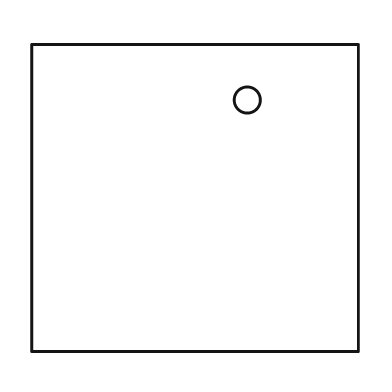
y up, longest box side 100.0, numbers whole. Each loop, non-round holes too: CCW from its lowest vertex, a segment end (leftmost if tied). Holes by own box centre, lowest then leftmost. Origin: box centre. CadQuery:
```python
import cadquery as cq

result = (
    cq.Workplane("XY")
    .moveTo(-50.0, -47.0)
    .lineTo(50.0, -47.0)
    .lineTo(50.0, 47.0)
    .lineTo(-50.0, 47.0)
    .close()
    .moveTo(16.0, 30.0)
    .circle(4.0)
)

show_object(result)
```